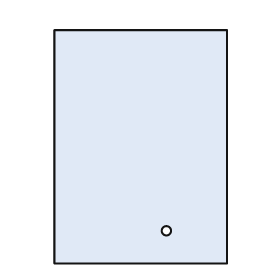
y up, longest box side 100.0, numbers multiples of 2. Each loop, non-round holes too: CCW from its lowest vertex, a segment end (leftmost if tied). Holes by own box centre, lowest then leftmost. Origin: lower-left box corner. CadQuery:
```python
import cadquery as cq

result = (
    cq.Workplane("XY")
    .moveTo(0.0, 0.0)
    .lineTo(74.0, 0.0)
    .lineTo(74.0, 100.0)
    .lineTo(0.0, 100.0)
    .close()
    .moveTo(48.0, 14.0)
    .circle(2.0)
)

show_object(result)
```